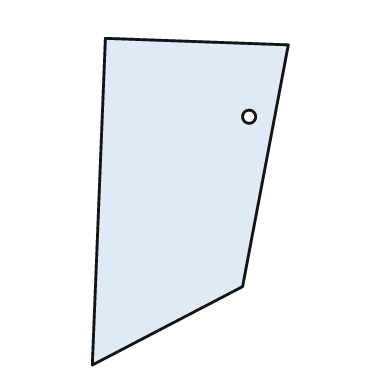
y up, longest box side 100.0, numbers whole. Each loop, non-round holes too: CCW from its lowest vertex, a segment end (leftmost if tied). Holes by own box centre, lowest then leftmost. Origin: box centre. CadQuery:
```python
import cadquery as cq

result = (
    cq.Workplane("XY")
    .moveTo(-30.0, -50.0)
    .lineTo(16.0, -26.0)
    .lineTo(30.0, 48.0)
    .lineTo(-26.0, 50.0)
    .close()
    .moveTo(18.0, 26.0)
    .circle(2.0)
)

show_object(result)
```